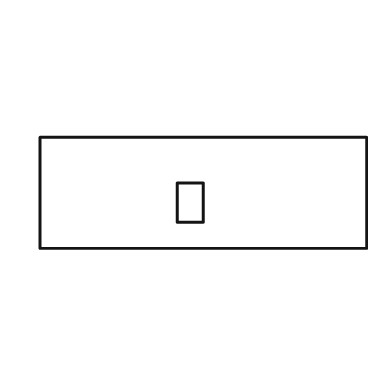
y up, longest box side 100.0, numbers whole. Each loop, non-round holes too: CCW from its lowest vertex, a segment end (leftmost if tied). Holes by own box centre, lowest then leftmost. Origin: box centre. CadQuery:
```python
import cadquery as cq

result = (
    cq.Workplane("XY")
    .moveTo(-50.0, -17.0)
    .lineTo(50.0, -17.0)
    .lineTo(50.0, 17.0)
    .lineTo(-50.0, 17.0)
    .close()
    .moveTo(-8.0, -9.0)
    .lineTo(0.0, -9.0)
    .lineTo(0.0, 3.0)
    .lineTo(-8.0, 3.0)
    .close()
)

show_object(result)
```